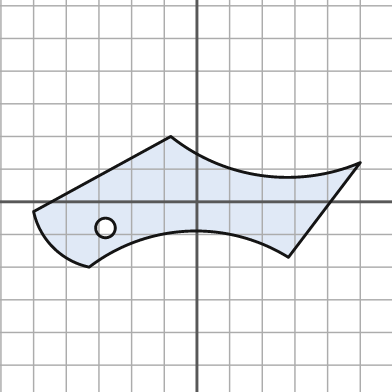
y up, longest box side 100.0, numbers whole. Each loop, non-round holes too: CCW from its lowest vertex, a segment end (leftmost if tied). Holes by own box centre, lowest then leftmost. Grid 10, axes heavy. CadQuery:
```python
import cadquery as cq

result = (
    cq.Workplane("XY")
    .moveTo(-33.0, -20.0)
    .threePointArc((-3.0, -9.0), (28.0, -17.0))
    .lineTo(50.0, 12.0)
    .threePointArc((20.0, 8.0), (-8.0, 20.0))
    .lineTo(-50.0, -3.0)
    .threePointArc((-44.0, -14.0), (-33.0, -20.0))
    .close()
    .moveTo(-28.0, -8.0)
    .circle(3.0)
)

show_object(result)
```